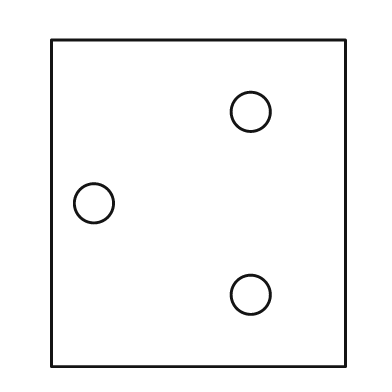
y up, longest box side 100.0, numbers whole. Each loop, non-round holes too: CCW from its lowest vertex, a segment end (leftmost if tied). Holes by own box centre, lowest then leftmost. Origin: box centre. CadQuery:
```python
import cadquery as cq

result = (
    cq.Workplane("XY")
    .moveTo(-45.0, -50.0)
    .lineTo(45.0, -50.0)
    .lineTo(45.0, 50.0)
    .lineTo(-45.0, 50.0)
    .close()
    .moveTo(16.0, -28.0)
    .circle(6.0)
    .moveTo(-32.0, 0.0)
    .circle(6.0)
    .moveTo(16.0, 28.0)
    .circle(6.0)
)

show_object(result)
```